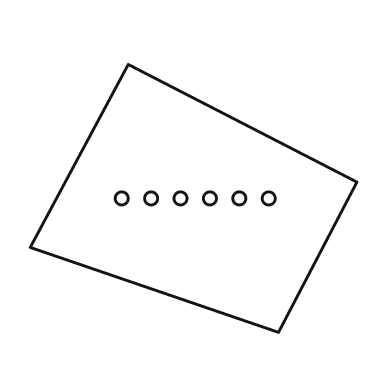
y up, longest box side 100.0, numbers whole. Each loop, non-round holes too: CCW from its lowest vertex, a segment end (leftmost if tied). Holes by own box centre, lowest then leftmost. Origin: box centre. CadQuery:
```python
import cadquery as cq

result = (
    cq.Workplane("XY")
    .moveTo(26.0, -41.0)
    .lineTo(50.0, 5.0)
    .lineTo(-20.0, 41.0)
    .lineTo(-50.0, -15.0)
    .close()
    .moveTo(-22.0, 0.0)
    .circle(2.0)
    .moveTo(-13.0, 0.0)
    .circle(2.0)
    .moveTo(-4.0, 0.0)
    .circle(2.0)
    .moveTo(5.0, 0.0)
    .circle(2.0)
    .moveTo(14.0, 0.0)
    .circle(2.0)
    .moveTo(23.0, 0.0)
    .circle(2.0)
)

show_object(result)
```